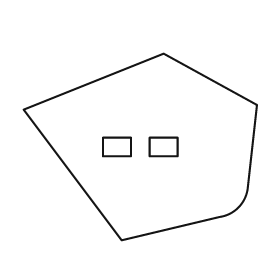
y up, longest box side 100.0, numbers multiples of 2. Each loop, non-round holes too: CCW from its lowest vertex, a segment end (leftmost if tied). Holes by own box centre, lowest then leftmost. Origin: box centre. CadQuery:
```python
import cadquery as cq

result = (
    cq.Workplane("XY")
    .moveTo(-8.0, -40.0)
    .lineTo(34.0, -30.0)
    .threePointArc((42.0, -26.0), (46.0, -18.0))
    .lineTo(50.0, 18.0)
    .lineTo(10.0, 40.0)
    .lineTo(-50.0, 16.0)
    .close()
    .moveTo(-16.0, -4.0)
    .lineTo(-4.0, -4.0)
    .lineTo(-4.0, 4.0)
    .lineTo(-16.0, 4.0)
    .close()
    .moveTo(4.0, -4.0)
    .lineTo(16.0, -4.0)
    .lineTo(16.0, 4.0)
    .lineTo(4.0, 4.0)
    .close()
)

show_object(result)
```